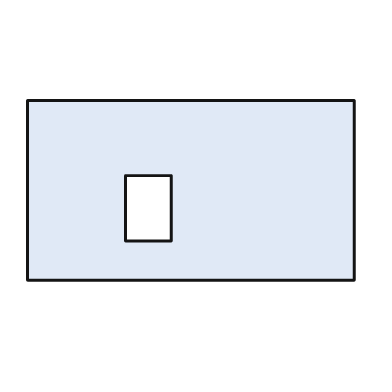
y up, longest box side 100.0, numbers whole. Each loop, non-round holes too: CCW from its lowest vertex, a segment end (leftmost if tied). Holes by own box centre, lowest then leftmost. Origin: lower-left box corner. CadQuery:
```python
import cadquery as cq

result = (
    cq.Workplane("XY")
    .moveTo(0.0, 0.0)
    .lineTo(100.0, 0.0)
    .lineTo(100.0, 55.0)
    .lineTo(0.0, 55.0)
    .close()
    .moveTo(30.0, 12.0)
    .lineTo(44.0, 12.0)
    .lineTo(44.0, 32.0)
    .lineTo(30.0, 32.0)
    .close()
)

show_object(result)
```